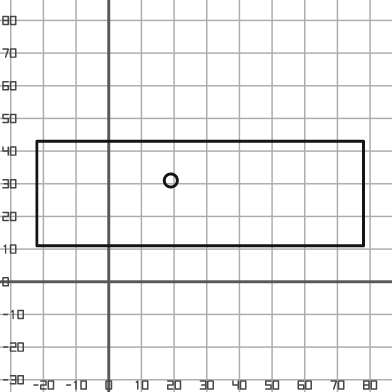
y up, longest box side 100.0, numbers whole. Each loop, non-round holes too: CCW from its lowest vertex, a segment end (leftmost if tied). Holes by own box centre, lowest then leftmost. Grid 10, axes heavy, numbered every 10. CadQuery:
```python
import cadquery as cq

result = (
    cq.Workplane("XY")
    .moveTo(-22.0, 11.0)
    .lineTo(78.0, 11.0)
    .lineTo(78.0, 43.0)
    .lineTo(-22.0, 43.0)
    .close()
    .moveTo(19.0, 31.0)
    .circle(2.0)
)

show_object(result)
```